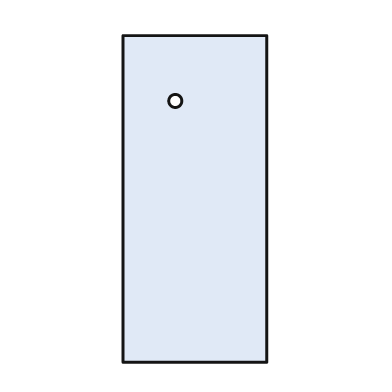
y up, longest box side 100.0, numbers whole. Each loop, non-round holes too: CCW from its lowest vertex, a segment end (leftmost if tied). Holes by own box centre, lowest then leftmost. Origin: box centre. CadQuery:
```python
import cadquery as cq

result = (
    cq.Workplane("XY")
    .moveTo(-22.0, -50.0)
    .lineTo(22.0, -50.0)
    .lineTo(22.0, 50.0)
    .lineTo(-22.0, 50.0)
    .close()
    .moveTo(-6.0, 30.0)
    .circle(2.0)
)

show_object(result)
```